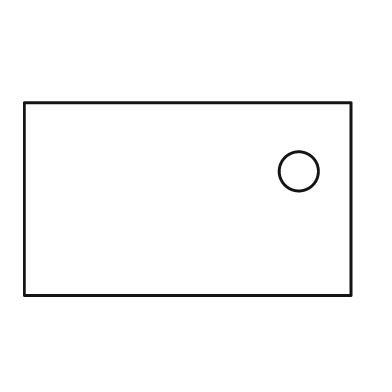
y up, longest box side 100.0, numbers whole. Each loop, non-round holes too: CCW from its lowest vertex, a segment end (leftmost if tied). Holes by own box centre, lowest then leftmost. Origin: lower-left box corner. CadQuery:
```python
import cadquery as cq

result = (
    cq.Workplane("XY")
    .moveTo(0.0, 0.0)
    .lineTo(100.0, 0.0)
    .lineTo(100.0, 59.0)
    .lineTo(0.0, 59.0)
    .close()
    .moveTo(84.0, 38.0)
    .circle(6.0)
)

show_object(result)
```